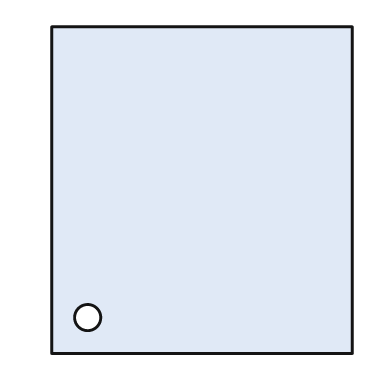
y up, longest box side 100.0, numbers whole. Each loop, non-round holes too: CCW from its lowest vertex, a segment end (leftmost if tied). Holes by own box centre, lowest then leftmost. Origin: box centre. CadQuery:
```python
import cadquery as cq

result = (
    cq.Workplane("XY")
    .moveTo(-46.0, -50.0)
    .lineTo(46.0, -50.0)
    .lineTo(46.0, 50.0)
    .lineTo(-46.0, 50.0)
    .close()
    .moveTo(-35.0, -39.0)
    .circle(4.0)
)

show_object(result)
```